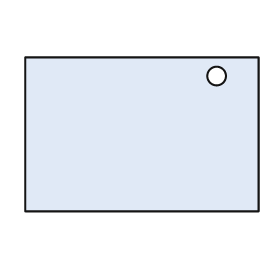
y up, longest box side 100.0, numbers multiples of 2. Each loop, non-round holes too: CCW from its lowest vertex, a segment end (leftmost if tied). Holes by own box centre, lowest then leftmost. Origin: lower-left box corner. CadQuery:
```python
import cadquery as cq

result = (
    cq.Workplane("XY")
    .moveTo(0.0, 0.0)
    .lineTo(100.0, 0.0)
    .lineTo(100.0, 66.0)
    .lineTo(0.0, 66.0)
    .close()
    .moveTo(82.0, 58.0)
    .circle(4.0)
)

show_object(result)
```